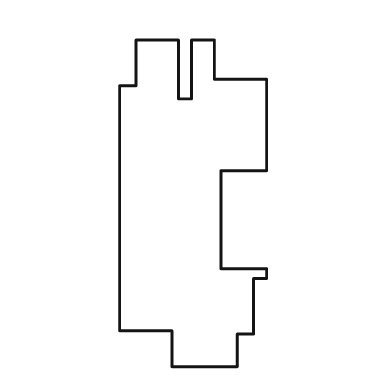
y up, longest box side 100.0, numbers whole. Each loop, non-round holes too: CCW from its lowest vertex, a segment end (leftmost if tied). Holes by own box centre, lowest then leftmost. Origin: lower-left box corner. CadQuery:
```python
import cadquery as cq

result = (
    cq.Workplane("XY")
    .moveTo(16.0, 0.0)
    .lineTo(36.0, 0.0)
    .lineTo(36.0, 10.0)
    .lineTo(41.0, 10.0)
    .lineTo(41.0, 27.0)
    .lineTo(45.0, 27.0)
    .lineTo(45.0, 30.0)
    .lineTo(31.0, 30.0)
    .lineTo(31.0, 60.0)
    .lineTo(45.0, 60.0)
    .lineTo(45.0, 88.0)
    .lineTo(29.0, 88.0)
    .lineTo(29.0, 100.0)
    .lineTo(22.0, 100.0)
    .lineTo(22.0, 82.0)
    .lineTo(18.0, 82.0)
    .lineTo(18.0, 100.0)
    .lineTo(5.0, 100.0)
    .lineTo(5.0, 86.0)
    .lineTo(0.0, 86.0)
    .lineTo(0.0, 11.0)
    .lineTo(16.0, 11.0)
    .close()
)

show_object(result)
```